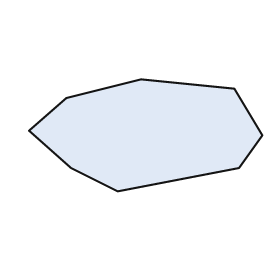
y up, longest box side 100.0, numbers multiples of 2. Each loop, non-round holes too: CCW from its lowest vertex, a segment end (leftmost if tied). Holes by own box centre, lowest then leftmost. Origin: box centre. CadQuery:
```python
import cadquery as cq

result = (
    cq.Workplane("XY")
    .moveTo(-12.0, -24.0)
    .lineTo(40.0, -14.0)
    .lineTo(50.0, 0.0)
    .lineTo(38.0, 20.0)
    .lineTo(-2.0, 24.0)
    .lineTo(-34.0, 16.0)
    .lineTo(-50.0, 2.0)
    .lineTo(-32.0, -14.0)
    .close()
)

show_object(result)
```